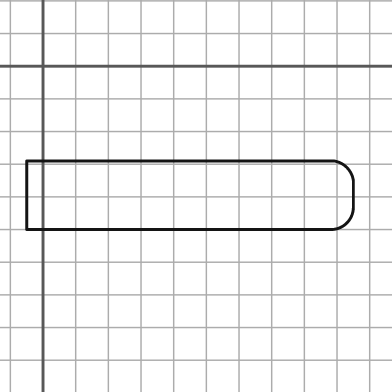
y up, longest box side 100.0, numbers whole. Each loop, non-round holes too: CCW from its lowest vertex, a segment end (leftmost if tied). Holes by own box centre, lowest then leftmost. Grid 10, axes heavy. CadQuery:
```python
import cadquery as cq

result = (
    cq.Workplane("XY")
    .moveTo(-5.0, -50.0)
    .lineTo(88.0, -50.0)
    .threePointArc((93.0, -48.0), (95.0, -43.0))
    .lineTo(95.0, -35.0)
    .threePointArc((93.0, -31.0), (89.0, -29.0))
    .lineTo(-5.0, -29.0)
    .close()
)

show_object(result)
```